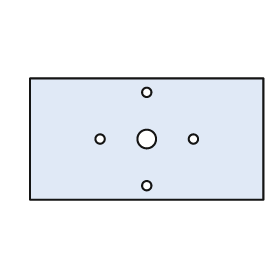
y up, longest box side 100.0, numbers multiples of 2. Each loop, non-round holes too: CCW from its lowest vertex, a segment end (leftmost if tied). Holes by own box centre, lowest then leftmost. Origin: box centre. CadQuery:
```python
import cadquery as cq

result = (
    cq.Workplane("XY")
    .moveTo(-50.0, -26.0)
    .lineTo(50.0, -26.0)
    .lineTo(50.0, 26.0)
    .lineTo(-50.0, 26.0)
    .close()
    .moveTo(0.0, -20.0)
    .circle(2.0)
    .moveTo(-20.0, 0.0)
    .circle(2.0)
    .moveTo(0.0, 0.0)
    .circle(4.0)
    .moveTo(20.0, 0.0)
    .circle(2.0)
    .moveTo(0.0, 20.0)
    .circle(2.0)
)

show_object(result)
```